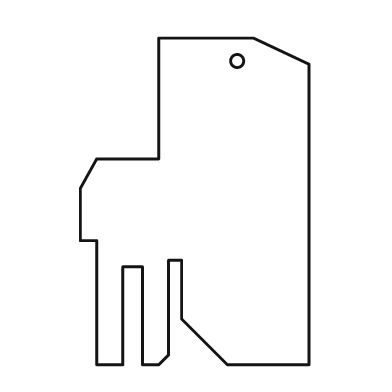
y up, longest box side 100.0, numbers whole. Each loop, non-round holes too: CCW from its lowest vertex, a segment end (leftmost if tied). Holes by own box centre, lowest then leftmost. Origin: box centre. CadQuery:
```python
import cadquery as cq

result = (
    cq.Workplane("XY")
    .moveTo(-30.0, -50.0)
    .lineTo(-22.0, -50.0)
    .lineTo(-22.0, -20.0)
    .lineTo(-16.0, -20.0)
    .lineTo(-16.0, -50.0)
    .lineTo(-11.0, -50.0)
    .lineTo(-8.0, -47.0)
    .lineTo(-8.0, -18.0)
    .lineTo(-4.0, -18.0)
    .lineTo(-4.0, -36.0)
    .lineTo(10.0, -50.0)
    .lineTo(35.0, -50.0)
    .lineTo(35.0, 42.0)
    .lineTo(18.0, 50.0)
    .lineTo(-11.0, 50.0)
    .lineTo(-11.0, 13.0)
    .lineTo(-30.0, 13.0)
    .lineTo(-35.0, 4.0)
    .lineTo(-35.0, -12.0)
    .lineTo(-30.0, -12.0)
    .close()
    .moveTo(13.0, 43.0)
    .circle(2.0)
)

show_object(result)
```